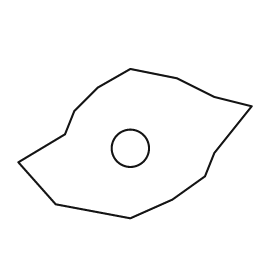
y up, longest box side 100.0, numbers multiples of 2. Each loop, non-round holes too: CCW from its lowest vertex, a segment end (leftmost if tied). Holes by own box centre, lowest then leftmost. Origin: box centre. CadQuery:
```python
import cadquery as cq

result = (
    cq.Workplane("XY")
    .moveTo(-2.0, -32.0)
    .lineTo(16.0, -24.0)
    .lineTo(30.0, -14.0)
    .lineTo(34.0, -4.0)
    .lineTo(50.0, 16.0)
    .lineTo(34.0, 20.0)
    .lineTo(18.0, 28.0)
    .lineTo(-2.0, 32.0)
    .lineTo(-16.0, 24.0)
    .lineTo(-26.0, 14.0)
    .lineTo(-30.0, 4.0)
    .lineTo(-50.0, -8.0)
    .lineTo(-34.0, -26.0)
    .close()
    .moveTo(-2.0, -2.0)
    .circle(8.0)
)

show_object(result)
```